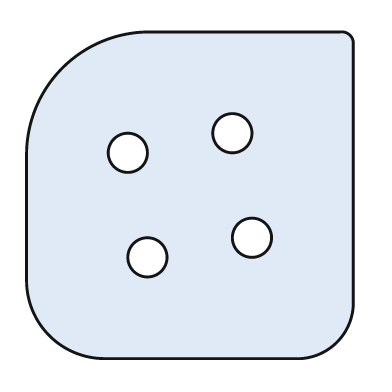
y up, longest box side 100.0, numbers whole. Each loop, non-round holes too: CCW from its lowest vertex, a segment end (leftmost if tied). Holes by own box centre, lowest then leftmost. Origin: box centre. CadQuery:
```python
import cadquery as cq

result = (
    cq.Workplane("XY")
    .moveTo(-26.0, -50.0)
    .lineTo(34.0, -50.0)
    .threePointArc((45.0, -45.0), (50.0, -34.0))
    .lineTo(50.0, 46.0)
    .threePointArc((49.0, 49.0), (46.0, 50.0))
    .lineTo(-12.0, 50.0)
    .threePointArc((-39.0, 39.0), (-50.0, 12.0))
    .lineTo(-50.0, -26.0)
    .threePointArc((-43.0, -43.0), (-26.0, -50.0))
    .close()
    .moveTo(-13.0, -19.0)
    .circle(6.0)
    .moveTo(19.0, -13.0)
    .circle(6.0)
    .moveTo(-19.0, 13.0)
    .circle(6.0)
    .moveTo(13.0, 19.0)
    .circle(6.0)
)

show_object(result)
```